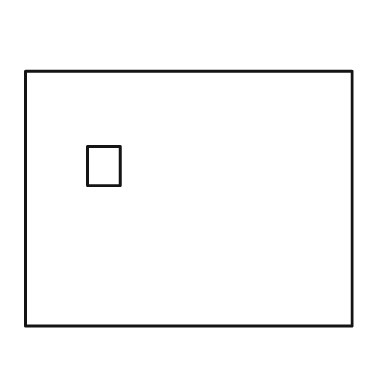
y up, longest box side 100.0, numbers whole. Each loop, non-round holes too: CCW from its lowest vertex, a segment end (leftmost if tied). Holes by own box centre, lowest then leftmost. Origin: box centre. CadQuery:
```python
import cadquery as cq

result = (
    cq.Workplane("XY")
    .moveTo(-50.0, -39.0)
    .lineTo(50.0, -39.0)
    .lineTo(50.0, 39.0)
    .lineTo(-50.0, 39.0)
    .close()
    .moveTo(-31.0, 4.0)
    .lineTo(-21.0, 4.0)
    .lineTo(-21.0, 16.0)
    .lineTo(-31.0, 16.0)
    .close()
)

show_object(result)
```